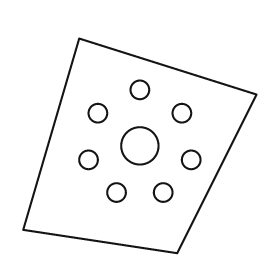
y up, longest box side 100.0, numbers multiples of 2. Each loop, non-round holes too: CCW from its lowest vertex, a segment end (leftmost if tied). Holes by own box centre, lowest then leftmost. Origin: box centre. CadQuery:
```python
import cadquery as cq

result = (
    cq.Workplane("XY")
    .moveTo(16.0, -46.0)
    .lineTo(50.0, 22.0)
    .lineTo(-26.0, 46.0)
    .lineTo(-50.0, -36.0)
    .close()
    .moveTo(-10.0, -20.0)
    .circle(4.0)
    .moveTo(10.0, -20.0)
    .circle(4.0)
    .moveTo(-22.0, -6.0)
    .circle(4.0)
    .moveTo(22.0, -6.0)
    .circle(4.0)
    .moveTo(0.0, 0.0)
    .circle(8.0)
    .moveTo(-18.0, 14.0)
    .circle(4.0)
    .moveTo(18.0, 14.0)
    .circle(4.0)
    .moveTo(0.0, 24.0)
    .circle(4.0)
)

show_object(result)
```